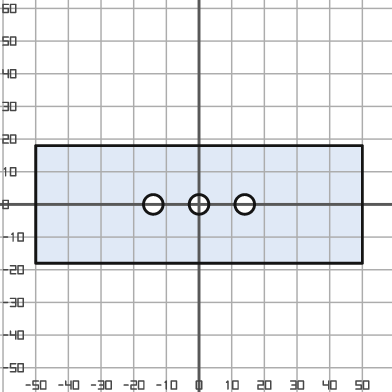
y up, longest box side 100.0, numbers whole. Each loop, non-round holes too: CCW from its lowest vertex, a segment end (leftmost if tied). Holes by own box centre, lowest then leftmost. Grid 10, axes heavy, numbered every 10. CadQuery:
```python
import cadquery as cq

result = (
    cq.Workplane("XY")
    .moveTo(-50.0, -18.0)
    .lineTo(50.0, -18.0)
    .lineTo(50.0, 18.0)
    .lineTo(-50.0, 18.0)
    .close()
    .moveTo(-14.0, 0.0)
    .circle(3.0)
    .moveTo(0.0, 0.0)
    .circle(3.0)
    .moveTo(14.0, 0.0)
    .circle(3.0)
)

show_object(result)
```